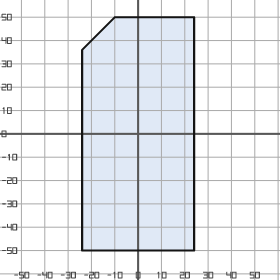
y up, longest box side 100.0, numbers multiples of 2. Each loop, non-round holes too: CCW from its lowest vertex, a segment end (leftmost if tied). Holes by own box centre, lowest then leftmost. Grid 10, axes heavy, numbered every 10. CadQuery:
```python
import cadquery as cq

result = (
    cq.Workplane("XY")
    .moveTo(-24.0, -50.0)
    .lineTo(24.0, -50.0)
    .lineTo(24.0, 50.0)
    .lineTo(-10.0, 50.0)
    .lineTo(-24.0, 36.0)
    .close()
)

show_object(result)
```